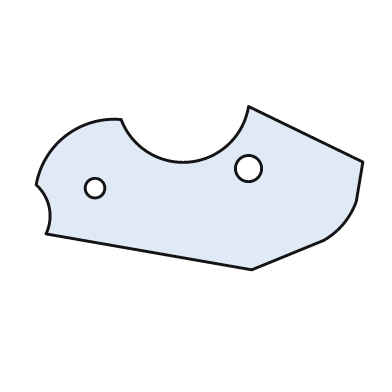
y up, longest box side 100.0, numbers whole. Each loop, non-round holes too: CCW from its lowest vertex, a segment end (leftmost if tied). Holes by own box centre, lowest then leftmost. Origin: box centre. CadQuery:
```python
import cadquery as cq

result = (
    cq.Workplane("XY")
    .moveTo(16.0, -25.0)
    .lineTo(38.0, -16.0)
    .threePointArc((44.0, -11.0), (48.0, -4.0))
    .lineTo(50.0, 8.0)
    .lineTo(15.0, 25.0)
    .threePointArc((-3.0, 8.0), (-24.0, 21.0))
    .threePointArc((-41.0, 16.0), (-50.0, 1.0))
    .threePointArc((-46.0, -6.0), (-47.0, -14.0))
    .close()
    .moveTo(-32.0, 0.0)
    .circle(3.0)
    .moveTo(15.0, 6.0)
    .circle(4.0)
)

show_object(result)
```